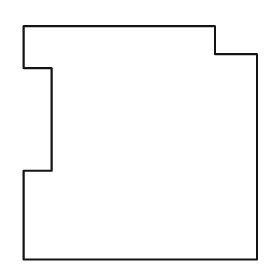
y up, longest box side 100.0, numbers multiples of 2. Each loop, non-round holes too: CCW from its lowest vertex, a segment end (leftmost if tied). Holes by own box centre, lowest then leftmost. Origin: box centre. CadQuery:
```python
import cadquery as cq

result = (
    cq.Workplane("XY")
    .moveTo(-50.0, -50.0)
    .lineTo(50.0, -50.0)
    .lineTo(50.0, 38.0)
    .lineTo(32.0, 38.0)
    .lineTo(32.0, 50.0)
    .lineTo(-50.0, 50.0)
    .lineTo(-50.0, 32.0)
    .lineTo(-38.0, 32.0)
    .lineTo(-38.0, -12.0)
    .lineTo(-50.0, -12.0)
    .close()
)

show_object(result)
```